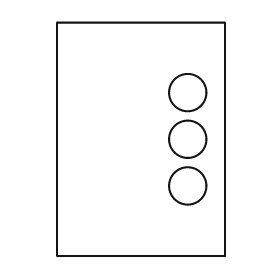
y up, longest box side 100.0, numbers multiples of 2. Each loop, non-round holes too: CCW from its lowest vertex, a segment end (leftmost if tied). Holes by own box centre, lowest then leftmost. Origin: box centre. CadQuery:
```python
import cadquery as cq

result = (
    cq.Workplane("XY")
    .moveTo(-36.0, -50.0)
    .lineTo(36.0, -50.0)
    .lineTo(36.0, 50.0)
    .lineTo(-36.0, 50.0)
    .close()
    .moveTo(20.0, -20.0)
    .circle(8.0)
    .moveTo(20.0, 0.0)
    .circle(8.0)
    .moveTo(20.0, 20.0)
    .circle(8.0)
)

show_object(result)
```